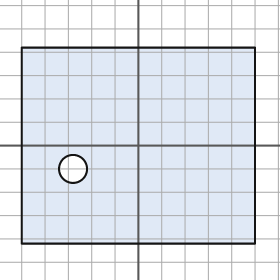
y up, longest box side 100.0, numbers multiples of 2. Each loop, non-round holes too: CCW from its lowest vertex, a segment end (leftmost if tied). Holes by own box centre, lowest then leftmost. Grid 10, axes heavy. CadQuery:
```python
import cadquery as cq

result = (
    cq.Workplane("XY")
    .moveTo(-50.0, -42.0)
    .lineTo(50.0, -42.0)
    .lineTo(50.0, 42.0)
    .lineTo(-50.0, 42.0)
    .close()
    .moveTo(-28.0, -10.0)
    .circle(6.0)
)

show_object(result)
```